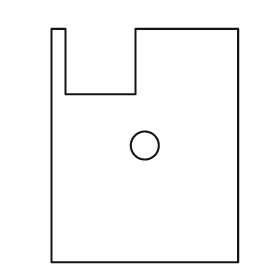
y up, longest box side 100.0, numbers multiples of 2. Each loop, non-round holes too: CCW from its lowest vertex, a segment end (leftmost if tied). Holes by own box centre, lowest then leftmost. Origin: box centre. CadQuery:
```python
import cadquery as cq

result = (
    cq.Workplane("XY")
    .moveTo(-40.0, -50.0)
    .lineTo(40.0, -50.0)
    .lineTo(40.0, 50.0)
    .lineTo(-4.0, 50.0)
    .lineTo(-4.0, 22.0)
    .lineTo(-34.0, 22.0)
    .lineTo(-34.0, 50.0)
    .lineTo(-40.0, 50.0)
    .close()
    .moveTo(0.0, 0.0)
    .circle(6.0)
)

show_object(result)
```